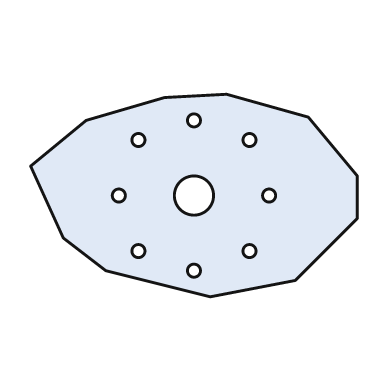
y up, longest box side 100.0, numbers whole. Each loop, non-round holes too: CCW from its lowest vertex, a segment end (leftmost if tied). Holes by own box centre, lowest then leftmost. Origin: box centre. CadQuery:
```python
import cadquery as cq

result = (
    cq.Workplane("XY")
    .moveTo(5.0, -31.0)
    .lineTo(31.0, -26.0)
    .lineTo(50.0, -7.0)
    .lineTo(50.0, 6.0)
    .lineTo(35.0, 24.0)
    .lineTo(10.0, 31.0)
    .lineTo(-9.0, 30.0)
    .lineTo(-33.0, 23.0)
    .lineTo(-50.0, 9.0)
    .lineTo(-40.0, -13.0)
    .lineTo(-27.0, -23.0)
    .close()
    .moveTo(0.0, -23.0)
    .circle(2.0)
    .moveTo(-17.0, -17.0)
    .circle(2.0)
    .moveTo(17.0, -17.0)
    .circle(2.0)
    .moveTo(-23.0, 0.0)
    .circle(2.0)
    .moveTo(0.0, 0.0)
    .circle(6.0)
    .moveTo(23.0, 0.0)
    .circle(2.0)
    .moveTo(-17.0, 17.0)
    .circle(2.0)
    .moveTo(17.0, 17.0)
    .circle(2.0)
    .moveTo(0.0, 23.0)
    .circle(2.0)
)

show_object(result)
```